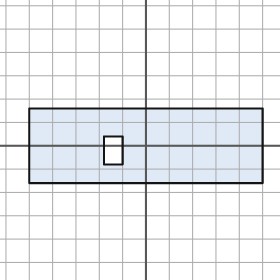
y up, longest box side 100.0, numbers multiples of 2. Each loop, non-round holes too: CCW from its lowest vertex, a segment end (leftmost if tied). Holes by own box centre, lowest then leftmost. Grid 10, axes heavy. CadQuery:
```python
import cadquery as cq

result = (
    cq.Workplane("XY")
    .moveTo(-50.0, -16.0)
    .lineTo(50.0, -16.0)
    .lineTo(50.0, 16.0)
    .lineTo(-50.0, 16.0)
    .close()
    .moveTo(-18.0, -8.0)
    .lineTo(-10.0, -8.0)
    .lineTo(-10.0, 4.0)
    .lineTo(-18.0, 4.0)
    .close()
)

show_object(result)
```